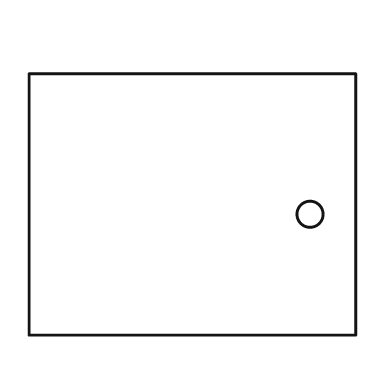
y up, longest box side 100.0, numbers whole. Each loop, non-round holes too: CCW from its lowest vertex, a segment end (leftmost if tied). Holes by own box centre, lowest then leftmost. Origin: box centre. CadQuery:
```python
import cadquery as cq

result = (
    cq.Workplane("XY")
    .moveTo(-50.0, -40.0)
    .lineTo(50.0, -40.0)
    .lineTo(50.0, 40.0)
    .lineTo(-50.0, 40.0)
    .close()
    .moveTo(36.0, -3.0)
    .circle(4.0)
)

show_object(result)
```